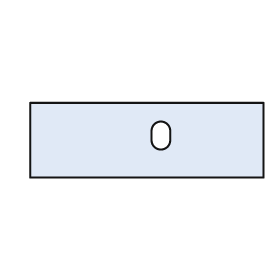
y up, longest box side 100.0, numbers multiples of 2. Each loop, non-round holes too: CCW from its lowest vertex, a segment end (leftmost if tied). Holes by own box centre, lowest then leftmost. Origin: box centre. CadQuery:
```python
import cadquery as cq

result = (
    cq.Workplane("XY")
    .moveTo(-50.0, -16.0)
    .lineTo(50.0, -16.0)
    .lineTo(50.0, 16.0)
    .lineTo(-50.0, 16.0)
    .close()
    .moveTo(2.0, 0.0)
    .threePointArc((6.0, -4.0), (10.0, 0.0))
    .lineTo(10.0, 4.0)
    .threePointArc((6.0, 8.0), (2.0, 4.0))
    .close()
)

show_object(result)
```